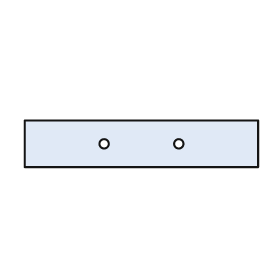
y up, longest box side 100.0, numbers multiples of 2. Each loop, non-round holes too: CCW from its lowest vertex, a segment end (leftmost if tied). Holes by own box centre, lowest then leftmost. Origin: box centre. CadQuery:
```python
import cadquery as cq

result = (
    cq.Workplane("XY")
    .moveTo(-50.0, -10.0)
    .lineTo(50.0, -10.0)
    .lineTo(50.0, 10.0)
    .lineTo(-50.0, 10.0)
    .close()
    .moveTo(-16.0, 0.0)
    .circle(2.0)
    .moveTo(16.0, 0.0)
    .circle(2.0)
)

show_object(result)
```